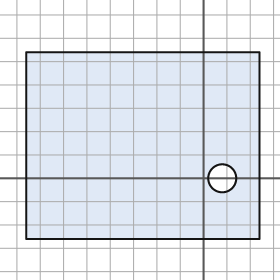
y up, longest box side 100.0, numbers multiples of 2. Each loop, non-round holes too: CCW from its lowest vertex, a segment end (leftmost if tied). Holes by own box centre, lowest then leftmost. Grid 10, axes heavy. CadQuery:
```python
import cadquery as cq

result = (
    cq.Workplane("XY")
    .moveTo(-76.0, -26.0)
    .lineTo(24.0, -26.0)
    .lineTo(24.0, 54.0)
    .lineTo(-76.0, 54.0)
    .close()
    .moveTo(8.0, 0.0)
    .circle(6.0)
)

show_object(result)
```